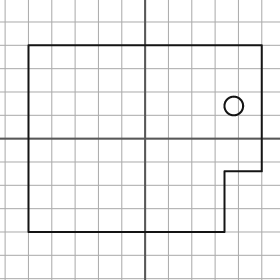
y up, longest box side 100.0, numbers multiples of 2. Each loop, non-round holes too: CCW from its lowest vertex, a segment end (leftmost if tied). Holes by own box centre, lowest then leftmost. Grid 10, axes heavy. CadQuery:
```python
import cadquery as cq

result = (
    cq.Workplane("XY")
    .moveTo(-50.0, -40.0)
    .lineTo(34.0, -40.0)
    .lineTo(34.0, -14.0)
    .lineTo(50.0, -14.0)
    .lineTo(50.0, 40.0)
    .lineTo(-50.0, 40.0)
    .close()
    .moveTo(38.0, 14.0)
    .circle(4.0)
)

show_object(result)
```